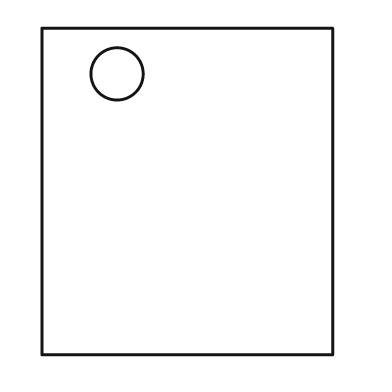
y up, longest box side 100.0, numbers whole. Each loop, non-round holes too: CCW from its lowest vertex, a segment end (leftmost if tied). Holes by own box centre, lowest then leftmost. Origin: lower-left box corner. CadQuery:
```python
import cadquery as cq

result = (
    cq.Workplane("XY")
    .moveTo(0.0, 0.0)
    .lineTo(89.0, 0.0)
    .lineTo(89.0, 100.0)
    .lineTo(0.0, 100.0)
    .close()
    .moveTo(23.0, 86.0)
    .circle(8.0)
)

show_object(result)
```